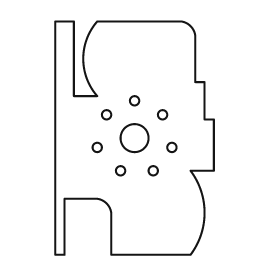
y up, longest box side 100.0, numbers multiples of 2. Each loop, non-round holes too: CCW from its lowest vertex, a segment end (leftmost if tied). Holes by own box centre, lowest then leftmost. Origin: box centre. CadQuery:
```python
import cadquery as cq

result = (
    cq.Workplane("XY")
    .moveTo(-34.0, -50.0)
    .lineTo(-30.0, -50.0)
    .lineTo(-30.0, -26.0)
    .lineTo(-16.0, -26.0)
    .threePointArc((-12.0, -28.0), (-10.0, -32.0))
    .lineTo(-10.0, -50.0)
    .lineTo(24.0, -50.0)
    .threePointArc((30.0, -32.0), (24.0, -14.0))
    .lineTo(34.0, -14.0)
    .lineTo(34.0, 8.0)
    .lineTo(30.0, 8.0)
    .lineTo(30.0, 24.0)
    .lineTo(26.0, 24.0)
    .lineTo(26.0, 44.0)
    .threePointArc((24.0, 48.0), (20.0, 50.0))
    .lineTo(-16.0, 50.0)
    .threePointArc((-22.0, 34.0), (-16.0, 18.0))
    .lineTo(-26.0, 18.0)
    .lineTo(-26.0, 50.0)
    .lineTo(-34.0, 50.0)
    .close()
    .moveTo(-6.0, -14.0)
    .circle(2.0)
    .moveTo(8.0, -14.0)
    .circle(2.0)
    .moveTo(-16.0, -4.0)
    .circle(2.0)
    .moveTo(16.0, -4.0)
    .circle(2.0)
    .moveTo(0.0, 0.0)
    .circle(6.0)
    .moveTo(-12.0, 10.0)
    .circle(2.0)
    .moveTo(12.0, 10.0)
    .circle(2.0)
    .moveTo(0.0, 16.0)
    .circle(2.0)
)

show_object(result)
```